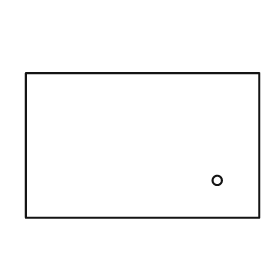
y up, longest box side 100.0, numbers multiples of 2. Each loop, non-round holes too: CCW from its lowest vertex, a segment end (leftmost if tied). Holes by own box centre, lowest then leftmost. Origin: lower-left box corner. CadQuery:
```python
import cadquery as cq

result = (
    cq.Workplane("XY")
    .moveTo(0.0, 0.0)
    .lineTo(100.0, 0.0)
    .lineTo(100.0, 62.0)
    .lineTo(0.0, 62.0)
    .close()
    .moveTo(82.0, 16.0)
    .circle(2.0)
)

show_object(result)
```